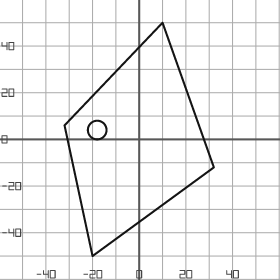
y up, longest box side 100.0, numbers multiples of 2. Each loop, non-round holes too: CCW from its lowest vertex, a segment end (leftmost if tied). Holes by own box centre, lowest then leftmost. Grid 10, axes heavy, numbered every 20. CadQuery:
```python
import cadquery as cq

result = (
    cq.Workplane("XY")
    .moveTo(-20.0, -50.0)
    .lineTo(32.0, -12.0)
    .lineTo(10.0, 50.0)
    .lineTo(-32.0, 6.0)
    .close()
    .moveTo(-18.0, 4.0)
    .circle(4.0)
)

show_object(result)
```